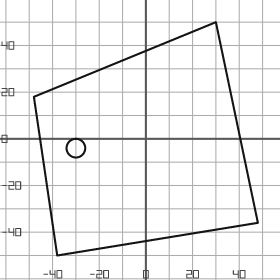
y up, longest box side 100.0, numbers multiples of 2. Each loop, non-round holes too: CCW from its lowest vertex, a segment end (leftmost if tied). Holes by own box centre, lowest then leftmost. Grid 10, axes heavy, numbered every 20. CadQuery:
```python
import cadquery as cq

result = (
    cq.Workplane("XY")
    .moveTo(-38.0, -50.0)
    .lineTo(48.0, -36.0)
    .lineTo(30.0, 50.0)
    .lineTo(-48.0, 18.0)
    .close()
    .moveTo(-30.0, -4.0)
    .circle(4.0)
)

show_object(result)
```